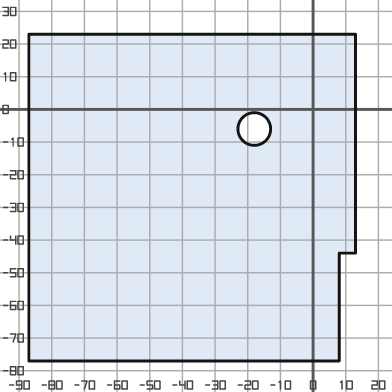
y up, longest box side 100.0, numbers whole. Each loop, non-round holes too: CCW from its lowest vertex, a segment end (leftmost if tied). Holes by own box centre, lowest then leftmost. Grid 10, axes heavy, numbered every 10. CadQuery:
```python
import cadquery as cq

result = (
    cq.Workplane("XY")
    .moveTo(-87.0, -77.0)
    .lineTo(8.0, -77.0)
    .lineTo(8.0, -44.0)
    .lineTo(13.0, -44.0)
    .lineTo(13.0, 23.0)
    .lineTo(-87.0, 23.0)
    .close()
    .moveTo(-18.0, -6.0)
    .circle(5.0)
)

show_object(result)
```